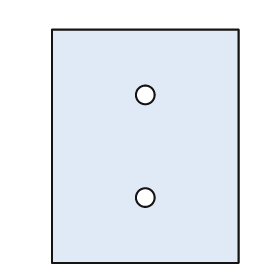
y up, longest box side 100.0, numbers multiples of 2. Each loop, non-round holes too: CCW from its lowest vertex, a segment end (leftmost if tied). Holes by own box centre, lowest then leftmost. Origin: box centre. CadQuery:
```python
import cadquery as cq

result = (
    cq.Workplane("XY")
    .moveTo(-40.0, -50.0)
    .lineTo(40.0, -50.0)
    .lineTo(40.0, 50.0)
    .lineTo(-40.0, 50.0)
    .close()
    .moveTo(0.0, -22.0)
    .circle(4.0)
    .moveTo(0.0, 22.0)
    .circle(4.0)
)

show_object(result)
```